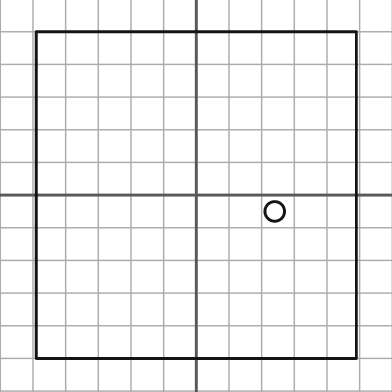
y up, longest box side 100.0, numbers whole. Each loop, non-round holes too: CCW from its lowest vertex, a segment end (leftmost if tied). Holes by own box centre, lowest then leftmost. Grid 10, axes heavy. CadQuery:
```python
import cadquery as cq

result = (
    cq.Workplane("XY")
    .moveTo(-49.0, -50.0)
    .lineTo(49.0, -50.0)
    .lineTo(49.0, 50.0)
    .lineTo(-49.0, 50.0)
    .close()
    .moveTo(24.0, -5.0)
    .circle(3.0)
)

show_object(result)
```